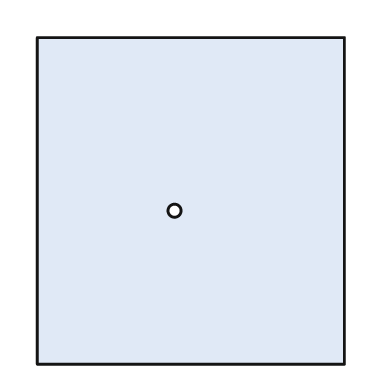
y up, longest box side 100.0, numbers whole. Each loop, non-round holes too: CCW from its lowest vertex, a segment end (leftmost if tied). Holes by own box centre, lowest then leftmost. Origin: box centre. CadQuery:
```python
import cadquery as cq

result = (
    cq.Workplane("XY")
    .moveTo(-47.0, -50.0)
    .lineTo(47.0, -50.0)
    .lineTo(47.0, 50.0)
    .lineTo(-47.0, 50.0)
    .close()
    .moveTo(-5.0, -3.0)
    .circle(2.0)
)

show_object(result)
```